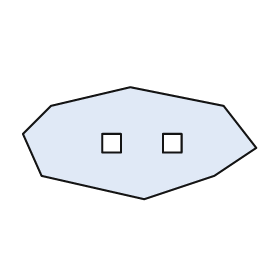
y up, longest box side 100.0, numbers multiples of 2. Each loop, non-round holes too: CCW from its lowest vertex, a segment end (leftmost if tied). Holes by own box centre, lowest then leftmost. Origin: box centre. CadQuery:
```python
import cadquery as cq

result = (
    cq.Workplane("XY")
    .moveTo(2.0, -24.0)
    .lineTo(32.0, -14.0)
    .lineTo(50.0, -2.0)
    .lineTo(36.0, 16.0)
    .lineTo(-4.0, 24.0)
    .lineTo(-38.0, 16.0)
    .lineTo(-50.0, 4.0)
    .lineTo(-42.0, -14.0)
    .close()
    .moveTo(-16.0, -4.0)
    .lineTo(-8.0, -4.0)
    .lineTo(-8.0, 4.0)
    .lineTo(-16.0, 4.0)
    .close()
    .moveTo(10.0, -4.0)
    .lineTo(18.0, -4.0)
    .lineTo(18.0, 4.0)
    .lineTo(10.0, 4.0)
    .close()
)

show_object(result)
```